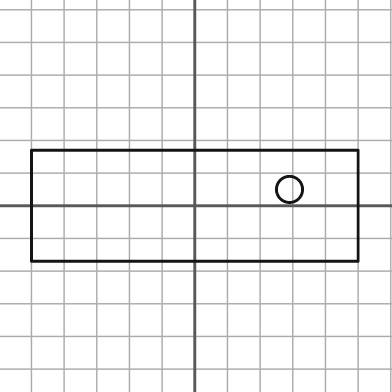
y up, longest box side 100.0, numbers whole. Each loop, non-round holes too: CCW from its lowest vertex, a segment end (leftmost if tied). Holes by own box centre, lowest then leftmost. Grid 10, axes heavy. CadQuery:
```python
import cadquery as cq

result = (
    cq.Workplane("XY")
    .moveTo(-50.0, -17.0)
    .lineTo(50.0, -17.0)
    .lineTo(50.0, 17.0)
    .lineTo(-50.0, 17.0)
    .close()
    .moveTo(29.0, 5.0)
    .circle(4.0)
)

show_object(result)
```